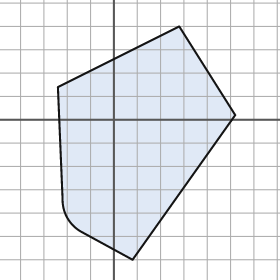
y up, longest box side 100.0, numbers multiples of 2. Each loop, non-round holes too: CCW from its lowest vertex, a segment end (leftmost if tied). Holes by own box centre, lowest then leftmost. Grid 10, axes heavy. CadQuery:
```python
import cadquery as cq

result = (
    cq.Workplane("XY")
    .moveTo(8.0, -60.0)
    .lineTo(52.0, 2.0)
    .lineTo(28.0, 40.0)
    .lineTo(-24.0, 14.0)
    .lineTo(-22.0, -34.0)
    .threePointArc((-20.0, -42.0), (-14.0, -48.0))
    .close()
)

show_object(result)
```